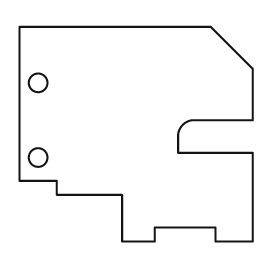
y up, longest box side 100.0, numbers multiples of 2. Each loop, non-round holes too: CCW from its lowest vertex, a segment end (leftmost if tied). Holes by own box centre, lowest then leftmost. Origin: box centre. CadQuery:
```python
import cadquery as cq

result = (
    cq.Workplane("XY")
    .moveTo(-6.0, -46.0)
    .lineTo(8.0, -46.0)
    .lineTo(8.0, -40.0)
    .lineTo(34.0, -40.0)
    .lineTo(34.0, -46.0)
    .lineTo(50.0, -46.0)
    .lineTo(50.0, -8.0)
    .lineTo(18.0, -8.0)
    .lineTo(18.0, 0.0)
    .threePointArc((20.0, 4.0), (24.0, 6.0))
    .lineTo(50.0, 6.0)
    .lineTo(50.0, 28.0)
    .lineTo(32.0, 46.0)
    .lineTo(-50.0, 46.0)
    .lineTo(-50.0, -20.0)
    .lineTo(-34.0, -20.0)
    .lineTo(-34.0, -26.0)
    .lineTo(-6.0, -26.0)
    .close()
    .moveTo(-42.0, -10.0)
    .circle(4.0)
    .moveTo(-42.0, 22.0)
    .circle(4.0)
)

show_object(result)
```